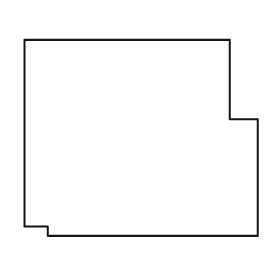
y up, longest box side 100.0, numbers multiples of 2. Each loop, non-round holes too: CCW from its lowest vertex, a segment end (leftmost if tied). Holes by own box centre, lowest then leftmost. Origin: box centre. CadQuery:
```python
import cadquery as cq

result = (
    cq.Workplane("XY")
    .moveTo(-40.0, -42.0)
    .lineTo(50.0, -42.0)
    .lineTo(50.0, 8.0)
    .lineTo(38.0, 8.0)
    .lineTo(38.0, 42.0)
    .lineTo(-50.0, 42.0)
    .lineTo(-50.0, -38.0)
    .lineTo(-40.0, -38.0)
    .close()
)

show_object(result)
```